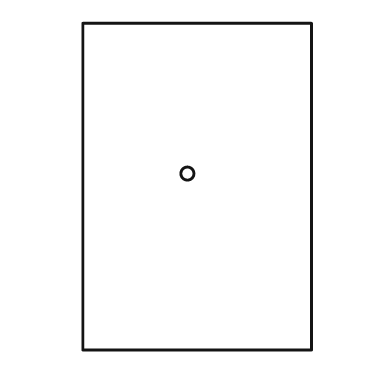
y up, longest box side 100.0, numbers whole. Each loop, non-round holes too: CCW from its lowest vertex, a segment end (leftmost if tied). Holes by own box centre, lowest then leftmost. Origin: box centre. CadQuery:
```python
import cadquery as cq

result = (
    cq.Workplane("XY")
    .moveTo(-35.0, -50.0)
    .lineTo(35.0, -50.0)
    .lineTo(35.0, 50.0)
    .lineTo(-35.0, 50.0)
    .close()
    .moveTo(-3.0, 4.0)
    .circle(2.0)
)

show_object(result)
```